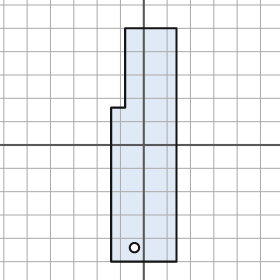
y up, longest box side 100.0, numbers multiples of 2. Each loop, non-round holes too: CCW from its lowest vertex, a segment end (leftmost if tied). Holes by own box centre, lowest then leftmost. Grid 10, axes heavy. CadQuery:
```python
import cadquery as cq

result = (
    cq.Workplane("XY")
    .moveTo(-14.0, -50.0)
    .lineTo(14.0, -50.0)
    .lineTo(14.0, 50.0)
    .lineTo(-8.0, 50.0)
    .lineTo(-8.0, 16.0)
    .lineTo(-14.0, 16.0)
    .close()
    .moveTo(-4.0, -44.0)
    .circle(2.0)
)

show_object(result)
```